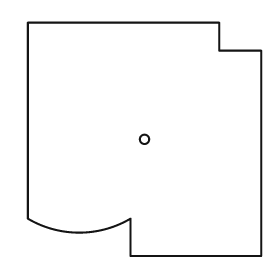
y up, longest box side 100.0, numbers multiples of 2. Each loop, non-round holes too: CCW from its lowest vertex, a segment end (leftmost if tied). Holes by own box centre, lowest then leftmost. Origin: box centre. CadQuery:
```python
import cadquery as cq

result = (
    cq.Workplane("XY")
    .moveTo(-6.0, -50.0)
    .lineTo(50.0, -50.0)
    .lineTo(50.0, 38.0)
    .lineTo(32.0, 38.0)
    .lineTo(32.0, 50.0)
    .lineTo(-50.0, 50.0)
    .lineTo(-50.0, -34.0)
    .threePointArc((-28.0, -40.0), (-6.0, -34.0))
    .close()
    .moveTo(0.0, 0.0)
    .circle(2.0)
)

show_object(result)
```